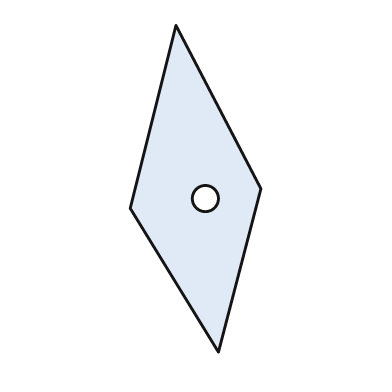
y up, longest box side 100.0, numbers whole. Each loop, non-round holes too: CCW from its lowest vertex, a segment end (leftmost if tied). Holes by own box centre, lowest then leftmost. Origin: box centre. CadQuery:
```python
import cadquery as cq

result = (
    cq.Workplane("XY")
    .moveTo(7.0, -50.0)
    .lineTo(20.0, 0.0)
    .lineTo(-6.0, 50.0)
    .lineTo(-20.0, -6.0)
    .close()
    .moveTo(3.0, -3.0)
    .circle(4.0)
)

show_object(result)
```